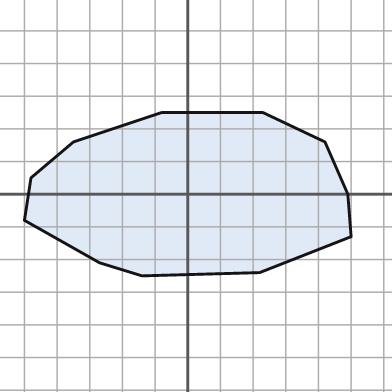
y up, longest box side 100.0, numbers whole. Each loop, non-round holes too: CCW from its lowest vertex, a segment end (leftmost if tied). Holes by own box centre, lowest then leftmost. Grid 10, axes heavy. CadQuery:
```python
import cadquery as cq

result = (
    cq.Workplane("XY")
    .moveTo(-14.0, -25.0)
    .lineTo(22.0, -24.0)
    .lineTo(50.0, -13.0)
    .lineTo(49.0, 0.0)
    .lineTo(42.0, 16.0)
    .lineTo(23.0, 25.0)
    .lineTo(-8.0, 25.0)
    .lineTo(-35.0, 16.0)
    .lineTo(-48.0, 5.0)
    .lineTo(-50.0, -8.0)
    .lineTo(-27.0, -21.0)
    .close()
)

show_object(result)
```